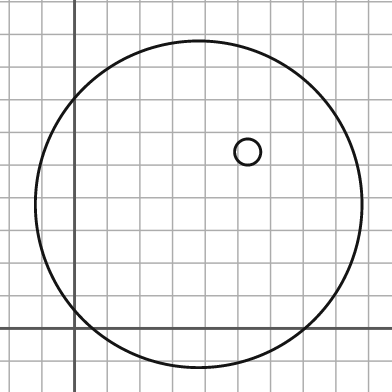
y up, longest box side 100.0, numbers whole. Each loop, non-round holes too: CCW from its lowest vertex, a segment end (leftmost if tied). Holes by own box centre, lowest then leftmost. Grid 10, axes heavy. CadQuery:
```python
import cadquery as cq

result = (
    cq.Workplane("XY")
    .moveTo(38.0, 38.0)
    .circle(50.0)
    .moveTo(53.0, 54.0)
    .circle(4.0)
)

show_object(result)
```